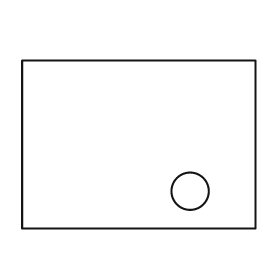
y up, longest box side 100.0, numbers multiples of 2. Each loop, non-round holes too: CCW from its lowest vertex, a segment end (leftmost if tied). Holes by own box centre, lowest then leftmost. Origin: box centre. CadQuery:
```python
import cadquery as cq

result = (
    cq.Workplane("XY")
    .moveTo(-50.0, -36.0)
    .lineTo(50.0, -36.0)
    .lineTo(50.0, 36.0)
    .lineTo(-50.0, 36.0)
    .close()
    .moveTo(22.0, -20.0)
    .circle(8.0)
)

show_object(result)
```